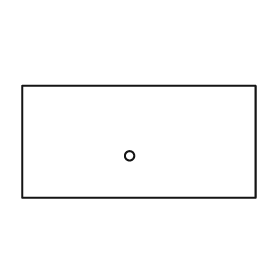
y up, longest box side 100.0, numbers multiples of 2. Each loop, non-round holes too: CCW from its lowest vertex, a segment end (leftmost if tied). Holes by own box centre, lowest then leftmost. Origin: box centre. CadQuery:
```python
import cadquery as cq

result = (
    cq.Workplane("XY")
    .moveTo(-50.0, -24.0)
    .lineTo(50.0, -24.0)
    .lineTo(50.0, 24.0)
    .lineTo(-50.0, 24.0)
    .close()
    .moveTo(-4.0, -6.0)
    .circle(2.0)
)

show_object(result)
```